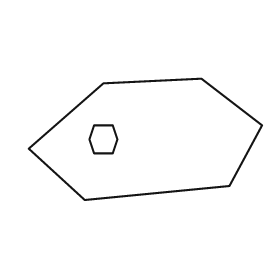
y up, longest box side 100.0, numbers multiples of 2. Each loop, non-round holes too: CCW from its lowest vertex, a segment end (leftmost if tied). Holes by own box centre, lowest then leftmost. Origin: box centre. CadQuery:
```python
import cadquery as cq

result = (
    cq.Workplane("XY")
    .moveTo(-26.0, -26.0)
    .lineTo(36.0, -20.0)
    .lineTo(50.0, 6.0)
    .lineTo(24.0, 26.0)
    .lineTo(-18.0, 24.0)
    .lineTo(-50.0, -4.0)
    .close()
    .moveTo(-22.0, -6.0)
    .lineTo(-14.0, -6.0)
    .lineTo(-12.0, 0.0)
    .lineTo(-14.0, 6.0)
    .lineTo(-22.0, 6.0)
    .lineTo(-24.0, 0.0)
    .close()
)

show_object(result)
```